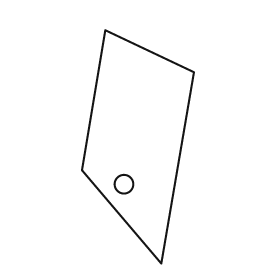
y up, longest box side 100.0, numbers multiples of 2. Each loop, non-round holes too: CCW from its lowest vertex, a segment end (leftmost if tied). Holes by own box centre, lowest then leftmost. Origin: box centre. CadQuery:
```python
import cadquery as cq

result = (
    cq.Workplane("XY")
    .moveTo(10.0, -50.0)
    .lineTo(24.0, 32.0)
    .lineTo(-14.0, 50.0)
    .lineTo(-24.0, -10.0)
    .close()
    .moveTo(-6.0, -16.0)
    .circle(4.0)
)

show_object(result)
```